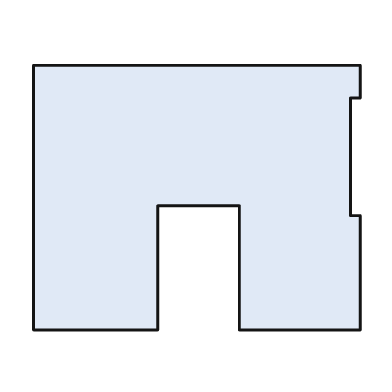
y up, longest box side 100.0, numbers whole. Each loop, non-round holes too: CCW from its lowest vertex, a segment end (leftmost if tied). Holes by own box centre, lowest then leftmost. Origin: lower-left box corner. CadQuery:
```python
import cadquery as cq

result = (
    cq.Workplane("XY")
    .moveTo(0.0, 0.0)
    .lineTo(38.0, 0.0)
    .lineTo(38.0, 38.0)
    .lineTo(63.0, 38.0)
    .lineTo(63.0, 0.0)
    .lineTo(100.0, 0.0)
    .lineTo(100.0, 35.0)
    .lineTo(97.0, 35.0)
    .lineTo(97.0, 71.0)
    .lineTo(100.0, 71.0)
    .lineTo(100.0, 81.0)
    .lineTo(0.0, 81.0)
    .close()
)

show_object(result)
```